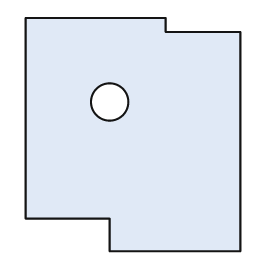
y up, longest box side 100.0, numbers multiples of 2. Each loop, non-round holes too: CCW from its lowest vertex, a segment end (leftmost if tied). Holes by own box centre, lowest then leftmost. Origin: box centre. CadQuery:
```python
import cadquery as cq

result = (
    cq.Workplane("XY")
    .moveTo(-10.0, -50.0)
    .lineTo(46.0, -50.0)
    .lineTo(46.0, 44.0)
    .lineTo(14.0, 44.0)
    .lineTo(14.0, 50.0)
    .lineTo(-46.0, 50.0)
    .lineTo(-46.0, -36.0)
    .lineTo(-10.0, -36.0)
    .close()
    .moveTo(-10.0, 14.0)
    .circle(8.0)
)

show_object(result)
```